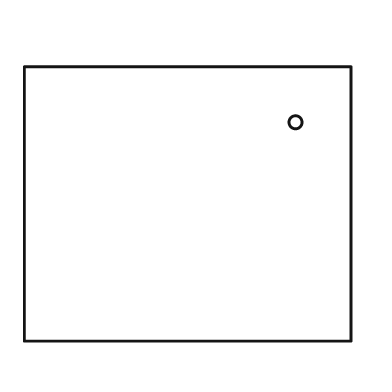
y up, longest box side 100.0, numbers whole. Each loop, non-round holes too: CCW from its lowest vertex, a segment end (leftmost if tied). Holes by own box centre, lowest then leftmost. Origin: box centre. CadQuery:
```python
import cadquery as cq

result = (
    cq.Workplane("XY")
    .moveTo(-50.0, -42.0)
    .lineTo(50.0, -42.0)
    .lineTo(50.0, 42.0)
    .lineTo(-50.0, 42.0)
    .close()
    .moveTo(33.0, 25.0)
    .circle(2.0)
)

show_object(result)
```